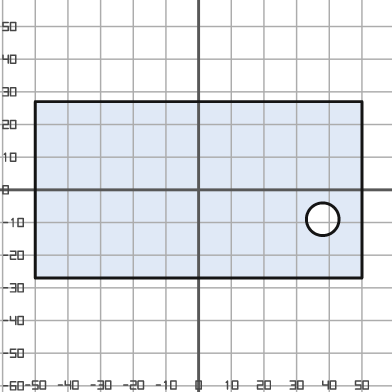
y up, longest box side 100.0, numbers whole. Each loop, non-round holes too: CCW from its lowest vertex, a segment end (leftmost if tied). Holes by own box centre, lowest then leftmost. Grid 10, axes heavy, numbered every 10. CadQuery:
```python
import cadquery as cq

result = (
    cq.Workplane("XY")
    .moveTo(-50.0, -27.0)
    .lineTo(50.0, -27.0)
    .lineTo(50.0, 27.0)
    .lineTo(-50.0, 27.0)
    .close()
    .moveTo(38.0, -9.0)
    .circle(5.0)
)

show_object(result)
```